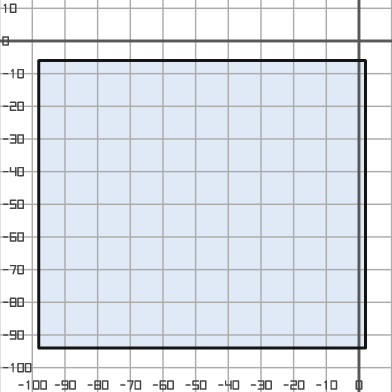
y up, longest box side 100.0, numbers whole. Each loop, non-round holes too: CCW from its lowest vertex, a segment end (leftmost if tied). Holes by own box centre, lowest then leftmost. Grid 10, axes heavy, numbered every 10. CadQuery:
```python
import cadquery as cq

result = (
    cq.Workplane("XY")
    .moveTo(-98.0, -94.0)
    .lineTo(2.0, -94.0)
    .lineTo(2.0, -6.0)
    .lineTo(-98.0, -6.0)
    .close()
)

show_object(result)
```